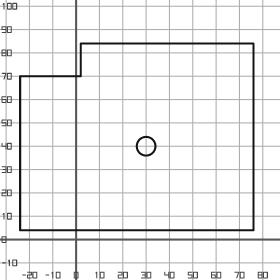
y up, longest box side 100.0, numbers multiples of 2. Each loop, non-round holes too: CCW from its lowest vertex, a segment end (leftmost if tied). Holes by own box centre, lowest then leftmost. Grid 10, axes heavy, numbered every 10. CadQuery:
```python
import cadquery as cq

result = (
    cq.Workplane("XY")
    .moveTo(-24.0, 4.0)
    .lineTo(76.0, 4.0)
    .lineTo(76.0, 84.0)
    .lineTo(2.0, 84.0)
    .lineTo(2.0, 70.0)
    .lineTo(-24.0, 70.0)
    .close()
    .moveTo(30.0, 40.0)
    .circle(4.0)
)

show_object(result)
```